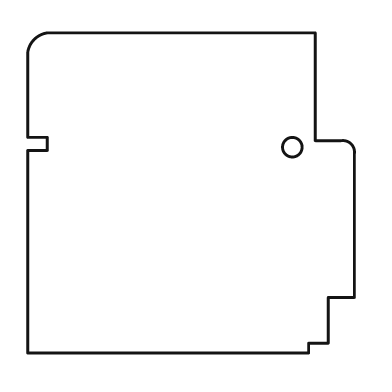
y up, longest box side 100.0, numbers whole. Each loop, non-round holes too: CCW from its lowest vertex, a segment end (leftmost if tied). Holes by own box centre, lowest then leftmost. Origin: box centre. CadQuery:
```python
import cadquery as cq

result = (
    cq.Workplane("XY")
    .moveTo(-50.0, -49.0)
    .lineTo(36.0, -49.0)
    .lineTo(36.0, -46.0)
    .lineTo(42.0, -46.0)
    .lineTo(42.0, -32.0)
    .lineTo(50.0, -32.0)
    .lineTo(50.0, 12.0)
    .threePointArc((49.0, 15.0), (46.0, 16.0))
    .lineTo(38.0, 16.0)
    .lineTo(38.0, 49.0)
    .lineTo(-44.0, 49.0)
    .threePointArc((-48.0, 47.0), (-50.0, 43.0))
    .lineTo(-50.0, 17.0)
    .lineTo(-44.0, 17.0)
    .lineTo(-44.0, 13.0)
    .lineTo(-50.0, 13.0)
    .close()
    .moveTo(31.0, 14.0)
    .circle(3.0)
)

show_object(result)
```